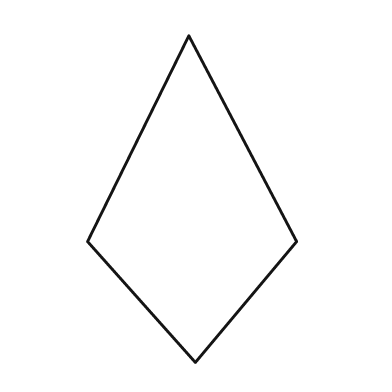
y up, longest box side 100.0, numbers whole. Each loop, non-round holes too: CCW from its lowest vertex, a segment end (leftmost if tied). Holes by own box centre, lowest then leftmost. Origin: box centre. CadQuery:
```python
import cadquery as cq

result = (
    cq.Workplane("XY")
    .moveTo(1.0, -50.0)
    .lineTo(32.0, -13.0)
    .lineTo(-1.0, 50.0)
    .lineTo(-32.0, -13.0)
    .close()
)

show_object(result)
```